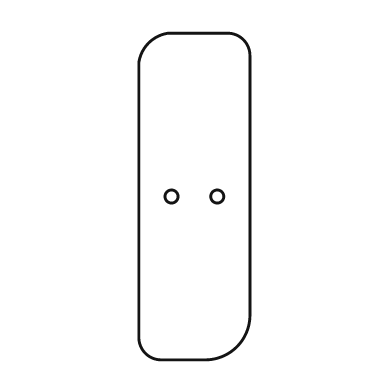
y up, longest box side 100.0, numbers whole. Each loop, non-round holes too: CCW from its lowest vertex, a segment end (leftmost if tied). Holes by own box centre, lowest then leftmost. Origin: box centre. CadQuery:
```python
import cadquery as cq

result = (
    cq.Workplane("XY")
    .moveTo(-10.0, -50.0)
    .lineTo(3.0, -50.0)
    .threePointArc((13.0, -46.0), (17.0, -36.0))
    .lineTo(17.0, 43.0)
    .threePointArc((15.0, 48.0), (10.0, 50.0))
    .lineTo(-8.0, 50.0)
    .threePointArc((-14.0, 47.0), (-17.0, 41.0))
    .lineTo(-17.0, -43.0)
    .threePointArc((-15.0, -48.0), (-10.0, -50.0))
    .close()
    .moveTo(-7.0, 0.0)
    .circle(2.0)
    .moveTo(7.0, 0.0)
    .circle(2.0)
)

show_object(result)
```